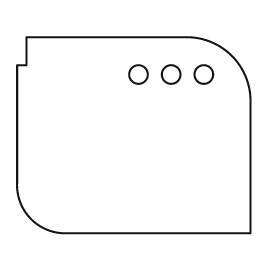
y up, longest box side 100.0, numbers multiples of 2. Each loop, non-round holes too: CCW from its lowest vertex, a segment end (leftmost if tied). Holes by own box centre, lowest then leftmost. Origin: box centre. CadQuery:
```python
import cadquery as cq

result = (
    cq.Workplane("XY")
    .moveTo(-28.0, -42.0)
    .lineTo(50.0, -42.0)
    .lineTo(50.0, 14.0)
    .threePointArc((42.0, 34.0), (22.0, 42.0))
    .lineTo(-46.0, 42.0)
    .lineTo(-46.0, 30.0)
    .lineTo(-50.0, 30.0)
    .lineTo(-50.0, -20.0)
    .threePointArc((-44.0, -36.0), (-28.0, -42.0))
    .close()
    .moveTo(2.0, 26.0)
    .circle(4.0)
    .moveTo(16.0, 26.0)
    .circle(4.0)
    .moveTo(30.0, 26.0)
    .circle(4.0)
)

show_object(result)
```